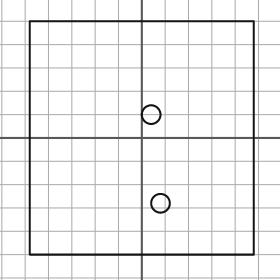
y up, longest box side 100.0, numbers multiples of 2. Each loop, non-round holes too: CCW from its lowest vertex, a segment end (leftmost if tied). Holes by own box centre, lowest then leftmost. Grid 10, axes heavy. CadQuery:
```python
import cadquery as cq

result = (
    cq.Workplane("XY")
    .moveTo(-48.0, -50.0)
    .lineTo(48.0, -50.0)
    .lineTo(48.0, 50.0)
    .lineTo(-48.0, 50.0)
    .close()
    .moveTo(8.0, -28.0)
    .circle(4.0)
    .moveTo(4.0, 10.0)
    .circle(4.0)
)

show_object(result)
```